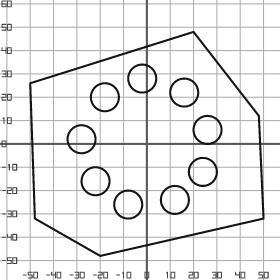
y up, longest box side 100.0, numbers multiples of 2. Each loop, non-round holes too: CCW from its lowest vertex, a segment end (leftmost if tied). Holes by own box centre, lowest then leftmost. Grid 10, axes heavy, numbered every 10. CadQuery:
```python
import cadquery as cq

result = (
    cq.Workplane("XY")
    .moveTo(-20.0, -48.0)
    .lineTo(50.0, -32.0)
    .lineTo(48.0, 12.0)
    .lineTo(20.0, 48.0)
    .lineTo(-50.0, 26.0)
    .lineTo(-48.0, -32.0)
    .close()
    .moveTo(-8.0, -26.0)
    .circle(6.0)
    .moveTo(12.0, -24.0)
    .circle(6.0)
    .moveTo(-22.0, -16.0)
    .circle(6.0)
    .moveTo(24.0, -12.0)
    .circle(6.0)
    .moveTo(-28.0, 2.0)
    .circle(6.0)
    .moveTo(26.0, 6.0)
    .circle(6.0)
    .moveTo(-18.0, 20.0)
    .circle(6.0)
    .moveTo(16.0, 22.0)
    .circle(6.0)
    .moveTo(-2.0, 28.0)
    .circle(6.0)
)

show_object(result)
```